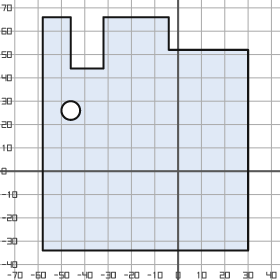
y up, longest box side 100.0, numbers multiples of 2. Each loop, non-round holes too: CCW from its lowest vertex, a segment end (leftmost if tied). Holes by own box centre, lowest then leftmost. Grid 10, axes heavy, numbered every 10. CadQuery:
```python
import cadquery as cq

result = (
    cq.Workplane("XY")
    .moveTo(-58.0, -34.0)
    .lineTo(30.0, -34.0)
    .lineTo(30.0, 52.0)
    .lineTo(-4.0, 52.0)
    .lineTo(-4.0, 66.0)
    .lineTo(-32.0, 66.0)
    .lineTo(-32.0, 44.0)
    .lineTo(-46.0, 44.0)
    .lineTo(-46.0, 66.0)
    .lineTo(-58.0, 66.0)
    .close()
    .moveTo(-46.0, 26.0)
    .circle(4.0)
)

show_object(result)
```